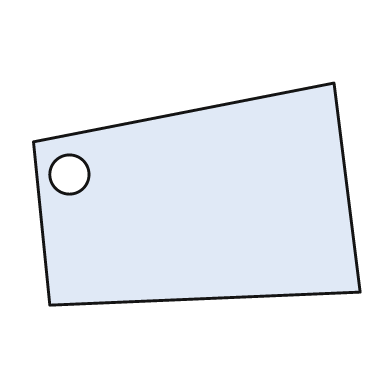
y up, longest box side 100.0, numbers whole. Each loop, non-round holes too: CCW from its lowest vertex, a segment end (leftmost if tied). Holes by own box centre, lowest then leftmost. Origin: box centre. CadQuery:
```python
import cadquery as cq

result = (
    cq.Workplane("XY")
    .moveTo(-45.0, -34.0)
    .lineTo(50.0, -30.0)
    .lineTo(42.0, 34.0)
    .lineTo(-50.0, 16.0)
    .close()
    .moveTo(-39.0, 6.0)
    .circle(6.0)
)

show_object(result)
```